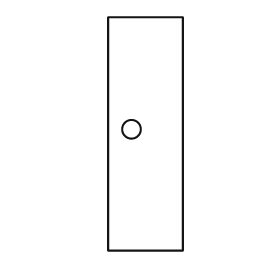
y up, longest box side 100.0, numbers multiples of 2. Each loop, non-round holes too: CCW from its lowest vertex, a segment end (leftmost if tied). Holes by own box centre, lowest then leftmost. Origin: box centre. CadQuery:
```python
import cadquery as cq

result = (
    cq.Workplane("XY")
    .moveTo(-16.0, -50.0)
    .lineTo(16.0, -50.0)
    .lineTo(16.0, 50.0)
    .lineTo(-16.0, 50.0)
    .close()
    .moveTo(-6.0, 2.0)
    .circle(4.0)
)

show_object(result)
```